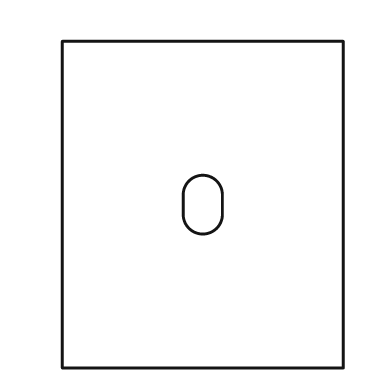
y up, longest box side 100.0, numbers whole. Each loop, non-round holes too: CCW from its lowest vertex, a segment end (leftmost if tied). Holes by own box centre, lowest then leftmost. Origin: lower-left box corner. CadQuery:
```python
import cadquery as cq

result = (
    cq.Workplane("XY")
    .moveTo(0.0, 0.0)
    .lineTo(86.0, 0.0)
    .lineTo(86.0, 100.0)
    .lineTo(0.0, 100.0)
    .close()
    .moveTo(37.0, 47.0)
    .threePointArc((43.0, 41.0), (49.0, 47.0))
    .lineTo(49.0, 53.0)
    .threePointArc((43.0, 59.0), (37.0, 53.0))
    .close()
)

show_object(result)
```